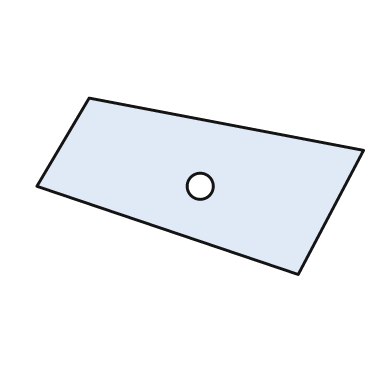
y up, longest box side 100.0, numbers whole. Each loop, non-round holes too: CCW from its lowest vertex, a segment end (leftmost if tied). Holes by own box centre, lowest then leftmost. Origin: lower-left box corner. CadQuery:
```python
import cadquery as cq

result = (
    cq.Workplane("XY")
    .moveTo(80.0, 0.0)
    .lineTo(100.0, 38.0)
    .lineTo(16.0, 54.0)
    .lineTo(0.0, 27.0)
    .close()
    .moveTo(50.0, 27.0)
    .circle(4.0)
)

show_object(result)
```